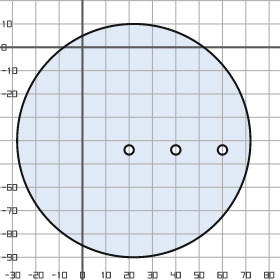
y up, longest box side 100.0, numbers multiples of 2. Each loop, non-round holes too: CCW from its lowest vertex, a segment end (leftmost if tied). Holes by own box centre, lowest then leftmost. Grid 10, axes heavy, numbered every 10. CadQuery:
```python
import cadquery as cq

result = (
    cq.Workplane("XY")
    .moveTo(22.0, -40.0)
    .circle(50.0)
    .moveTo(20.0, -44.0)
    .circle(2.0)
    .moveTo(40.0, -44.0)
    .circle(2.0)
    .moveTo(60.0, -44.0)
    .circle(2.0)
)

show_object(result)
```